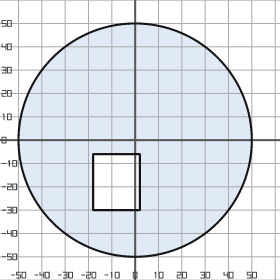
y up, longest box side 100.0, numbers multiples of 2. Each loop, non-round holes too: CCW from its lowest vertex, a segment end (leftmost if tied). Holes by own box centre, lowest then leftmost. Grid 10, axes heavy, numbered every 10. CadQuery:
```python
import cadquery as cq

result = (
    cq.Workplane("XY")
    .moveTo(0.0, 0.0)
    .circle(50.0)
    .moveTo(-18.0, -30.0)
    .lineTo(2.0, -30.0)
    .lineTo(2.0, -6.0)
    .lineTo(-18.0, -6.0)
    .close()
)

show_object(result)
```